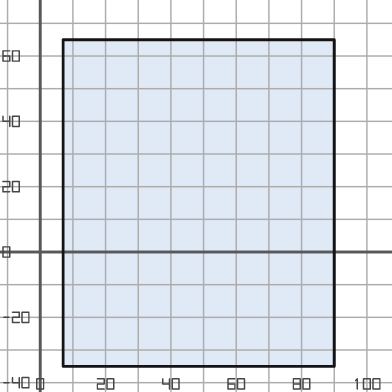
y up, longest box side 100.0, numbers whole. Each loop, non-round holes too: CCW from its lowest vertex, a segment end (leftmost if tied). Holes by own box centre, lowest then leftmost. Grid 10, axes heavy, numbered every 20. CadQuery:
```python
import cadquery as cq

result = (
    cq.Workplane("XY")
    .moveTo(7.0, -35.0)
    .lineTo(90.0, -35.0)
    .lineTo(90.0, 65.0)
    .lineTo(7.0, 65.0)
    .close()
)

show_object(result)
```